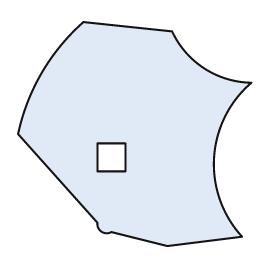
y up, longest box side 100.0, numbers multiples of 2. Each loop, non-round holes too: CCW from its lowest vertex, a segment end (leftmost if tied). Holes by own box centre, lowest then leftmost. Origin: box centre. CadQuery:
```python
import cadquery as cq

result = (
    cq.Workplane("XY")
    .moveTo(14.0, -48.0)
    .lineTo(46.0, -44.0)
    .threePointArc((34.0, -10.0), (50.0, 22.0))
    .threePointArc((30.0, 28.0), (16.0, 44.0))
    .lineTo(-22.0, 48.0)
    .threePointArc((-40.0, 26.0), (-50.0, 0.0))
    .lineTo(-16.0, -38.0)
    .threePointArc((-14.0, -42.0), (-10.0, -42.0))
    .close()
    .moveTo(-16.0, -16.0)
    .lineTo(-4.0, -16.0)
    .lineTo(-4.0, -4.0)
    .lineTo(-16.0, -4.0)
    .close()
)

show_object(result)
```